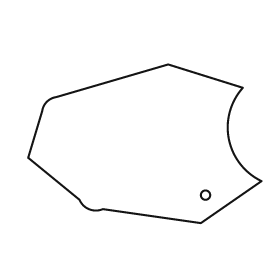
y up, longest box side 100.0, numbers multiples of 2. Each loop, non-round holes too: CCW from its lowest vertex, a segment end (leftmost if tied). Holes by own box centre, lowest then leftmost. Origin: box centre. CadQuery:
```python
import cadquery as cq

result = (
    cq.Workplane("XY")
    .moveTo(24.0, -34.0)
    .lineTo(50.0, -16.0)
    .threePointArc((36.0, 2.0), (42.0, 24.0))
    .lineTo(10.0, 34.0)
    .lineTo(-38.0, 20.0)
    .threePointArc((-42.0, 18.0), (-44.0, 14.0))
    .lineTo(-50.0, -6.0)
    .lineTo(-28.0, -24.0)
    .threePointArc((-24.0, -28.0), (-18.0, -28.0))
    .close()
    .moveTo(26.0, -22.0)
    .circle(2.0)
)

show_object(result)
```